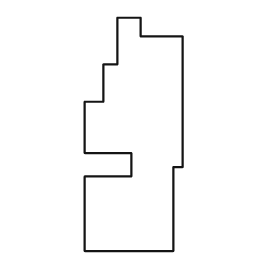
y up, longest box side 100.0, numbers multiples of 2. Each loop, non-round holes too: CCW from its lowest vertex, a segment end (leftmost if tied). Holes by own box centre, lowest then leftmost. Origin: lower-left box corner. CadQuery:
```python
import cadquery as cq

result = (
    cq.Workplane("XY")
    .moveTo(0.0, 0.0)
    .lineTo(38.0, 0.0)
    .lineTo(38.0, 36.0)
    .lineTo(42.0, 36.0)
    .lineTo(42.0, 92.0)
    .lineTo(24.0, 92.0)
    .lineTo(24.0, 100.0)
    .lineTo(14.0, 100.0)
    .lineTo(14.0, 80.0)
    .lineTo(8.0, 80.0)
    .lineTo(8.0, 64.0)
    .lineTo(0.0, 64.0)
    .lineTo(0.0, 42.0)
    .lineTo(20.0, 42.0)
    .lineTo(20.0, 32.0)
    .lineTo(0.0, 32.0)
    .close()
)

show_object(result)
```